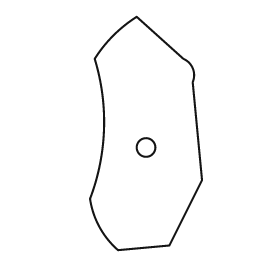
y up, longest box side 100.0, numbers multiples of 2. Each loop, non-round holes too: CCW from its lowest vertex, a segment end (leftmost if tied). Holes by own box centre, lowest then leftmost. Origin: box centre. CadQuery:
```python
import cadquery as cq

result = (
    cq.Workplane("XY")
    .moveTo(-12.0, -50.0)
    .lineTo(10.0, -48.0)
    .lineTo(24.0, -20.0)
    .lineTo(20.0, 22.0)
    .threePointArc((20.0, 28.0), (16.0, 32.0))
    .lineTo(-4.0, 50.0)
    .threePointArc((-14.0, 42.0), (-22.0, 32.0))
    .threePointArc((-18.0, 2.0), (-24.0, -28.0))
    .threePointArc((-20.0, -40.0), (-12.0, -50.0))
    .close()
    .moveTo(0.0, -6.0)
    .circle(4.0)
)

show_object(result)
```